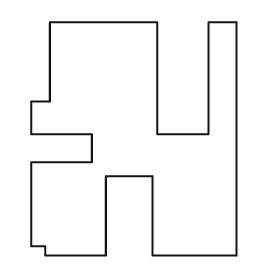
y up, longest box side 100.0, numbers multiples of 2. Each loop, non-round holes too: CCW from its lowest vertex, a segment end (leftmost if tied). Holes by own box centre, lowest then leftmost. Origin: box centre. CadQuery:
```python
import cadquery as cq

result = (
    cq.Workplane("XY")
    .moveTo(-38.0, -50.0)
    .lineTo(-12.0, -50.0)
    .lineTo(-12.0, -16.0)
    .lineTo(8.0, -16.0)
    .lineTo(8.0, -50.0)
    .lineTo(44.0, -50.0)
    .lineTo(44.0, 50.0)
    .lineTo(32.0, 50.0)
    .lineTo(32.0, 2.0)
    .lineTo(10.0, 2.0)
    .lineTo(10.0, 50.0)
    .lineTo(-36.0, 50.0)
    .lineTo(-36.0, 16.0)
    .lineTo(-44.0, 16.0)
    .lineTo(-44.0, 2.0)
    .lineTo(-18.0, 2.0)
    .lineTo(-18.0, -10.0)
    .lineTo(-44.0, -10.0)
    .lineTo(-44.0, -46.0)
    .lineTo(-38.0, -46.0)
    .close()
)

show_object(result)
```